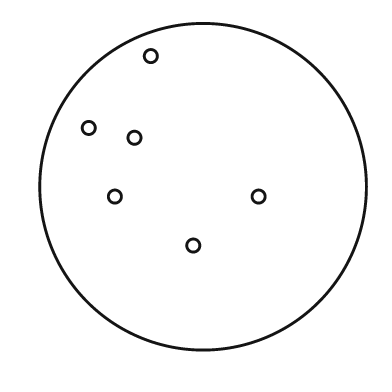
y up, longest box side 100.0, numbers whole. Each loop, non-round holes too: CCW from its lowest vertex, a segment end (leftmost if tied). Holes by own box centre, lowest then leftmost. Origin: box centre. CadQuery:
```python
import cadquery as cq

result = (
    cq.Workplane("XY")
    .moveTo(0.0, 0.0)
    .circle(50.0)
    .moveTo(-3.0, -18.0)
    .circle(2.0)
    .moveTo(-27.0, -3.0)
    .circle(2.0)
    .moveTo(17.0, -3.0)
    .circle(2.0)
    .moveTo(-21.0, 15.0)
    .circle(2.0)
    .moveTo(-35.0, 18.0)
    .circle(2.0)
    .moveTo(-16.0, 40.0)
    .circle(2.0)
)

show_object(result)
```